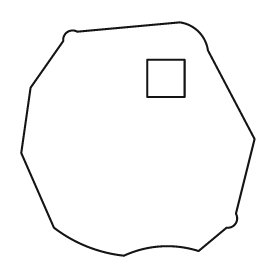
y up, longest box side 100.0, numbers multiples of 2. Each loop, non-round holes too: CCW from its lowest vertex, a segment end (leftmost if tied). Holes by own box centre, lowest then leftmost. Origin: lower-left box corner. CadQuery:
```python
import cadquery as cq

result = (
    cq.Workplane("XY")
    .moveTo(44.0, 0.0)
    .threePointArc((60.0, 4.0), (76.0, 2.0))
    .lineTo(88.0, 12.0)
    .threePointArc((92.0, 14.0), (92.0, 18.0))
    .lineTo(100.0, 50.0)
    .lineTo(80.0, 88.0)
    .threePointArc((76.0, 96.0), (68.0, 100.0))
    .lineTo(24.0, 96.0)
    .threePointArc((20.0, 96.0), (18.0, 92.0))
    .lineTo(4.0, 72.0)
    .lineTo(0.0, 44.0)
    .lineTo(14.0, 12.0)
    .threePointArc((28.0, 4.0), (44.0, 0.0))
    .close()
    .moveTo(54.0, 68.0)
    .lineTo(70.0, 68.0)
    .lineTo(70.0, 84.0)
    .lineTo(54.0, 84.0)
    .close()
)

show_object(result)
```